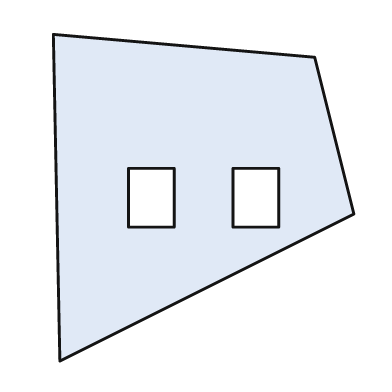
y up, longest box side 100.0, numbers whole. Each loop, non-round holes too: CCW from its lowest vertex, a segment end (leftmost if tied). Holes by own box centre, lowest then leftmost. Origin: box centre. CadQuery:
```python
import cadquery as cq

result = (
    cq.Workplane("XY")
    .moveTo(-44.0, -50.0)
    .lineTo(46.0, -5.0)
    .lineTo(34.0, 43.0)
    .lineTo(-46.0, 50.0)
    .close()
    .moveTo(-23.0, -9.0)
    .lineTo(-9.0, -9.0)
    .lineTo(-9.0, 9.0)
    .lineTo(-23.0, 9.0)
    .close()
    .moveTo(9.0, -9.0)
    .lineTo(23.0, -9.0)
    .lineTo(23.0, 9.0)
    .lineTo(9.0, 9.0)
    .close()
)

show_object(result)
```